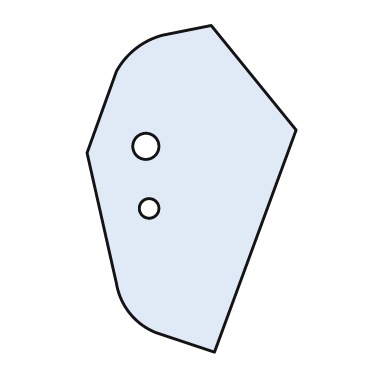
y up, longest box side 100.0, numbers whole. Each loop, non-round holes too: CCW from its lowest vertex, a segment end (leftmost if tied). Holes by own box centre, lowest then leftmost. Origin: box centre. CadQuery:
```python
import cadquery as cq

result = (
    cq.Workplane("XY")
    .moveTo(7.0, -50.0)
    .lineTo(32.0, 18.0)
    .lineTo(6.0, 50.0)
    .lineTo(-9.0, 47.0)
    .threePointArc((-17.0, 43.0), (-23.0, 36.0))
    .lineTo(-32.0, 11.0)
    .lineTo(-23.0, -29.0)
    .threePointArc((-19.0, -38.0), (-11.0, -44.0))
    .close()
    .moveTo(-13.0, -6.0)
    .circle(3.0)
    .moveTo(-14.0, 13.0)
    .circle(4.0)
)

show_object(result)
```